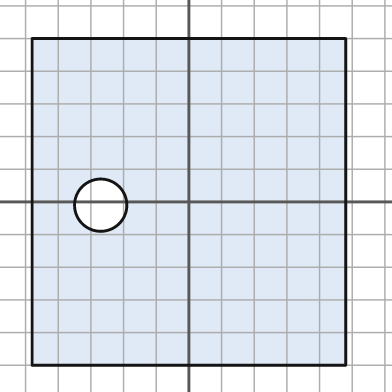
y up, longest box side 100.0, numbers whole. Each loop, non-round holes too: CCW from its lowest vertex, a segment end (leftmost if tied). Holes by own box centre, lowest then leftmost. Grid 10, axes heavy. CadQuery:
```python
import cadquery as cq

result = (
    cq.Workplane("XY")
    .moveTo(-48.0, -50.0)
    .lineTo(48.0, -50.0)
    .lineTo(48.0, 50.0)
    .lineTo(-48.0, 50.0)
    .close()
    .moveTo(-27.0, -1.0)
    .circle(8.0)
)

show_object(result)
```